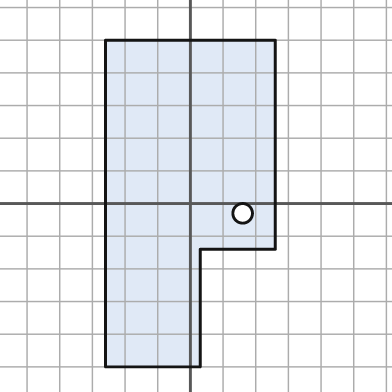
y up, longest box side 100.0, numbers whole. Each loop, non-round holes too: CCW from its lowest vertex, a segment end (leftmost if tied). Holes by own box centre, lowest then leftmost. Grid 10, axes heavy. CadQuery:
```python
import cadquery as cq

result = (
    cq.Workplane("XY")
    .moveTo(-26.0, -50.0)
    .lineTo(3.0, -50.0)
    .lineTo(3.0, -14.0)
    .lineTo(26.0, -14.0)
    .lineTo(26.0, 50.0)
    .lineTo(-26.0, 50.0)
    .close()
    .moveTo(16.0, -3.0)
    .circle(3.0)
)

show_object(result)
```